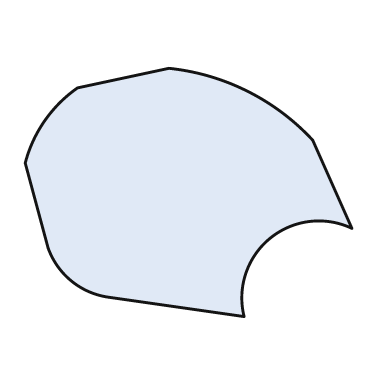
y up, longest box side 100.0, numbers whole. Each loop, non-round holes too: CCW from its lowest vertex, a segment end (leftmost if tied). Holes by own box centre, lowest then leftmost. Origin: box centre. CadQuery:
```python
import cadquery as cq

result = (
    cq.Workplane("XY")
    .moveTo(17.0, -38.0)
    .threePointArc((25.0, -14.0), (50.0, -11.0))
    .lineTo(38.0, 16.0)
    .threePointArc((18.0, 31.0), (-6.0, 38.0))
    .lineTo(-34.0, 32.0)
    .threePointArc((-44.0, 22.0), (-50.0, 9.0))
    .lineTo(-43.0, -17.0)
    .threePointArc((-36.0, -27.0), (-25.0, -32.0))
    .close()
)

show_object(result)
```